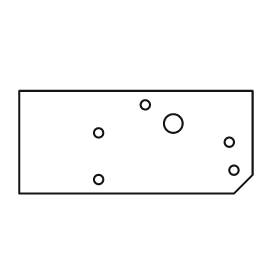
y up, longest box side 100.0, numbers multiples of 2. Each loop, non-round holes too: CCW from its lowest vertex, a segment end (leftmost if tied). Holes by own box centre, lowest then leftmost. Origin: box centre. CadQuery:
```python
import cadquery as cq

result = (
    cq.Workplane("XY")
    .moveTo(-50.0, -22.0)
    .lineTo(42.0, -22.0)
    .lineTo(50.0, -14.0)
    .lineTo(50.0, 22.0)
    .lineTo(-50.0, 22.0)
    .close()
    .moveTo(-16.0, -16.0)
    .circle(2.0)
    .moveTo(42.0, -12.0)
    .circle(2.0)
    .moveTo(40.0, 0.0)
    .circle(2.0)
    .moveTo(-16.0, 4.0)
    .circle(2.0)
    .moveTo(16.0, 8.0)
    .circle(4.0)
    .moveTo(4.0, 16.0)
    .circle(2.0)
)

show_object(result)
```